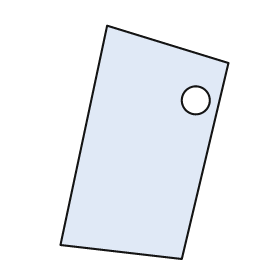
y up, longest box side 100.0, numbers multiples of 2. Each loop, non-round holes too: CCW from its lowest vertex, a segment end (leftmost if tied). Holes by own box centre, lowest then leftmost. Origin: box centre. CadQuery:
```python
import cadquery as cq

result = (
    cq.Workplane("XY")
    .moveTo(16.0, -50.0)
    .lineTo(36.0, 34.0)
    .lineTo(-16.0, 50.0)
    .lineTo(-36.0, -44.0)
    .close()
    .moveTo(22.0, 18.0)
    .circle(6.0)
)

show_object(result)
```